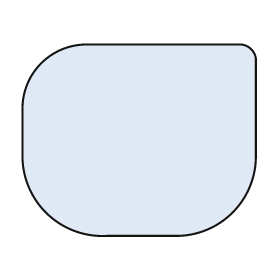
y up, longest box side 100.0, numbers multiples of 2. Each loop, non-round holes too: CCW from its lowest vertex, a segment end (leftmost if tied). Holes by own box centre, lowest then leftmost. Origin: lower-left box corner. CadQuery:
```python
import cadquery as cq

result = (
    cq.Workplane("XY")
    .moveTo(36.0, 0.0)
    .lineTo(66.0, 0.0)
    .threePointArc((90.0, 10.0), (100.0, 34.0))
    .lineTo(100.0, 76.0)
    .threePointArc((98.0, 80.0), (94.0, 82.0))
    .lineTo(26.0, 82.0)
    .threePointArc((8.0, 74.0), (0.0, 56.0))
    .lineTo(0.0, 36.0)
    .threePointArc((10.0, 10.0), (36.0, 0.0))
    .close()
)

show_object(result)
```